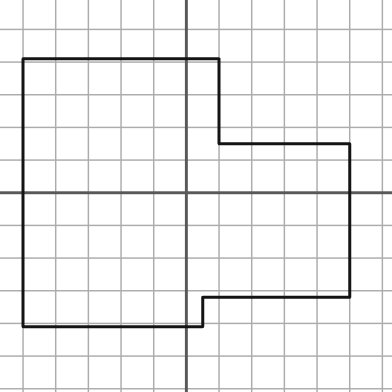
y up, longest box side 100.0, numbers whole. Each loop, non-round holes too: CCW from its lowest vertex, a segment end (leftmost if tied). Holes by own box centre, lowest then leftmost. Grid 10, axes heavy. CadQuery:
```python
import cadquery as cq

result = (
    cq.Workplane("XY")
    .moveTo(-50.0, -41.0)
    .lineTo(5.0, -41.0)
    .lineTo(5.0, -32.0)
    .lineTo(50.0, -32.0)
    .lineTo(50.0, 15.0)
    .lineTo(10.0, 15.0)
    .lineTo(10.0, 41.0)
    .lineTo(-50.0, 41.0)
    .close()
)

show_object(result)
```